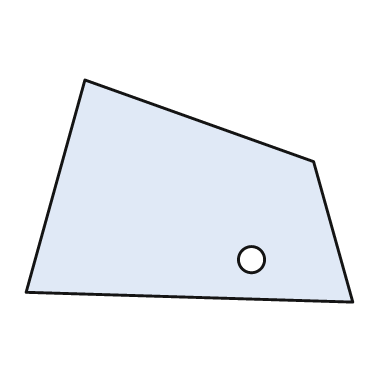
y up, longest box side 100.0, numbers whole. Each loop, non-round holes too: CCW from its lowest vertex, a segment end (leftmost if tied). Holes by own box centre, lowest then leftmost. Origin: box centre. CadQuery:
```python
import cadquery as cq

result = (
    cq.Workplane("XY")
    .moveTo(50.0, -34.0)
    .lineTo(38.0, 9.0)
    .lineTo(-32.0, 34.0)
    .lineTo(-50.0, -31.0)
    .close()
    .moveTo(19.0, -21.0)
    .circle(4.0)
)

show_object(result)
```